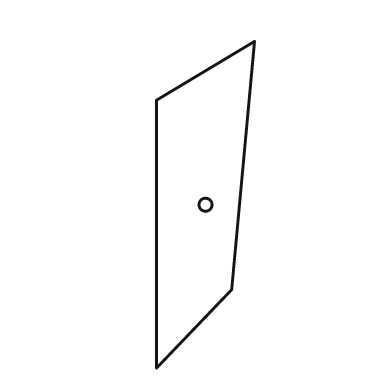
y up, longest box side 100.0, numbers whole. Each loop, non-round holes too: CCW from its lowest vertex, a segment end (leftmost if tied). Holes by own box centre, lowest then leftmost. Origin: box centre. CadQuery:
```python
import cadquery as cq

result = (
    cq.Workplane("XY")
    .moveTo(-15.0, -50.0)
    .lineTo(8.0, -26.0)
    .lineTo(15.0, 50.0)
    .lineTo(-15.0, 32.0)
    .close()
    .moveTo(0.0, 0.0)
    .circle(2.0)
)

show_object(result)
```